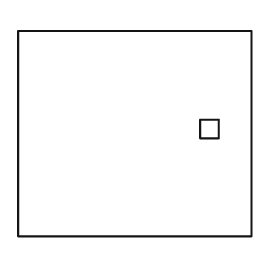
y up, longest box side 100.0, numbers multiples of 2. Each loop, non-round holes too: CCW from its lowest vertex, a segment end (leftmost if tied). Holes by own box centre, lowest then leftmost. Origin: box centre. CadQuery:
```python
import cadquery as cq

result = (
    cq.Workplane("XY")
    .moveTo(-50.0, -44.0)
    .lineTo(50.0, -44.0)
    .lineTo(50.0, 44.0)
    .lineTo(-50.0, 44.0)
    .close()
    .moveTo(28.0, -2.0)
    .lineTo(36.0, -2.0)
    .lineTo(36.0, 6.0)
    .lineTo(28.0, 6.0)
    .close()
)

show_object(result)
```